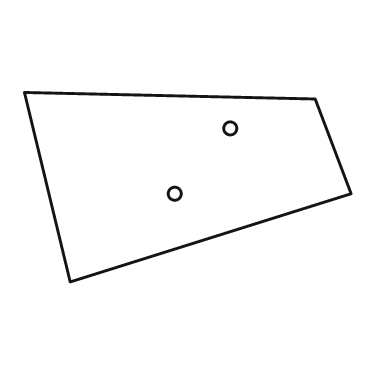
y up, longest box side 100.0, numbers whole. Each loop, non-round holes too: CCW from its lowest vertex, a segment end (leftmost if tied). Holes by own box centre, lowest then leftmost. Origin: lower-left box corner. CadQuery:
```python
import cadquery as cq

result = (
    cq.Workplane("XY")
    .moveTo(14.0, 0.0)
    .lineTo(100.0, 27.0)
    .lineTo(89.0, 56.0)
    .lineTo(0.0, 58.0)
    .close()
    .moveTo(46.0, 27.0)
    .circle(2.0)
    .moveTo(63.0, 47.0)
    .circle(2.0)
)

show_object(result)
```